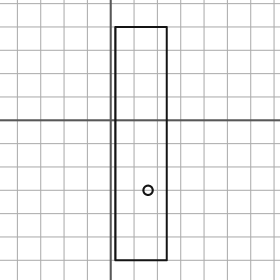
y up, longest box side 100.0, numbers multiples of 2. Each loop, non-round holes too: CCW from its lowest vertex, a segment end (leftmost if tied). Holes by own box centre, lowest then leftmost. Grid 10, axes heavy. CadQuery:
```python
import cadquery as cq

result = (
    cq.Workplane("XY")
    .moveTo(2.0, -60.0)
    .lineTo(24.0, -60.0)
    .lineTo(24.0, 40.0)
    .lineTo(2.0, 40.0)
    .close()
    .moveTo(16.0, -30.0)
    .circle(2.0)
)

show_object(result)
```